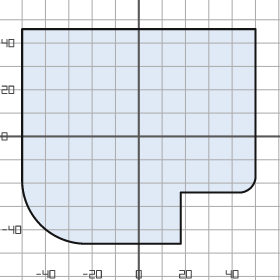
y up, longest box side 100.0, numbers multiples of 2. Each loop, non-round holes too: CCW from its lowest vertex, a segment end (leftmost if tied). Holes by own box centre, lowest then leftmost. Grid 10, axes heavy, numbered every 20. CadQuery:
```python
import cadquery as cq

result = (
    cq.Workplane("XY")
    .moveTo(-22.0, -46.0)
    .lineTo(18.0, -46.0)
    .lineTo(18.0, -24.0)
    .lineTo(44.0, -24.0)
    .threePointArc((48.0, -22.0), (50.0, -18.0))
    .lineTo(50.0, 46.0)
    .lineTo(-50.0, 46.0)
    .lineTo(-50.0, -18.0)
    .threePointArc((-42.0, -38.0), (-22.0, -46.0))
    .close()
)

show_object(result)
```